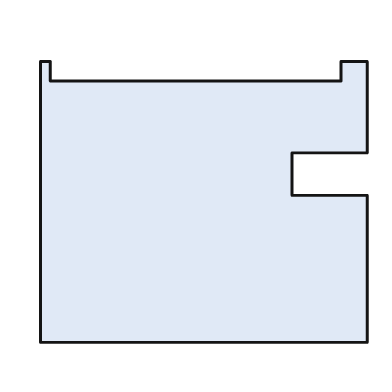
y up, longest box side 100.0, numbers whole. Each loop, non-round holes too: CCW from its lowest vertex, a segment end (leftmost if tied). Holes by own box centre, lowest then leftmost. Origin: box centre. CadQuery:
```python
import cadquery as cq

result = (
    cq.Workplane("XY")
    .moveTo(-50.0, -43.0)
    .lineTo(50.0, -43.0)
    .lineTo(50.0, 2.0)
    .lineTo(27.0, 2.0)
    .lineTo(27.0, 15.0)
    .lineTo(50.0, 15.0)
    .lineTo(50.0, 43.0)
    .lineTo(42.0, 43.0)
    .lineTo(42.0, 37.0)
    .lineTo(-47.0, 37.0)
    .lineTo(-47.0, 43.0)
    .lineTo(-50.0, 43.0)
    .close()
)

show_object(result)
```